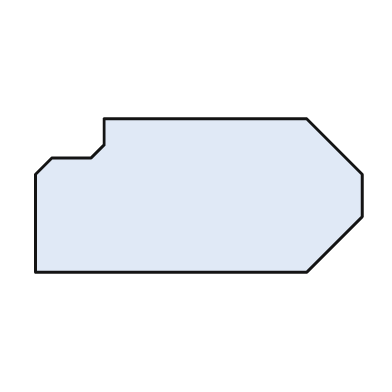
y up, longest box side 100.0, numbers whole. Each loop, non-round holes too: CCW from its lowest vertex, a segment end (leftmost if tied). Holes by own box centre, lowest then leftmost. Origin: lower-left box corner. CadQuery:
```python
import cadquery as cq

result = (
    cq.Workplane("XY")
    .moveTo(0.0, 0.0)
    .lineTo(83.0, 0.0)
    .lineTo(100.0, 17.0)
    .lineTo(100.0, 30.0)
    .lineTo(83.0, 47.0)
    .lineTo(21.0, 47.0)
    .lineTo(21.0, 39.0)
    .lineTo(17.0, 35.0)
    .lineTo(5.0, 35.0)
    .lineTo(0.0, 30.0)
    .close()
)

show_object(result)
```